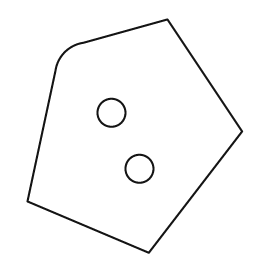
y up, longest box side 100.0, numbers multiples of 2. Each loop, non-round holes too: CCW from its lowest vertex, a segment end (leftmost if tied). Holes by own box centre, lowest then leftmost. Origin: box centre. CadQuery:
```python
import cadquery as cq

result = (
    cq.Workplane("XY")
    .moveTo(6.0, -50.0)
    .lineTo(46.0, 2.0)
    .lineTo(14.0, 50.0)
    .lineTo(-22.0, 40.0)
    .threePointArc((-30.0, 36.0), (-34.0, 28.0))
    .lineTo(-46.0, -28.0)
    .close()
    .moveTo(2.0, -14.0)
    .circle(6.0)
    .moveTo(-10.0, 10.0)
    .circle(6.0)
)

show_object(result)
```